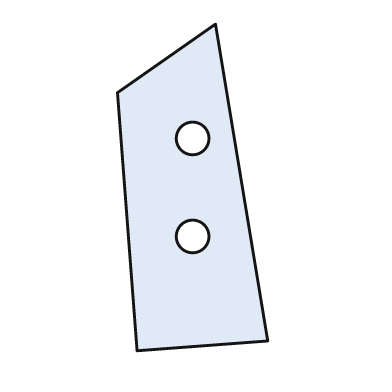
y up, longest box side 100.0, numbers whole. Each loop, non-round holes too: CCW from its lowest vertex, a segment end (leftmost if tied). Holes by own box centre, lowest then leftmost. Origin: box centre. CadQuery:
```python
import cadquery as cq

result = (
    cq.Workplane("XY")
    .moveTo(-17.0, -50.0)
    .lineTo(23.0, -47.0)
    .lineTo(7.0, 50.0)
    .lineTo(-23.0, 29.0)
    .close()
    .moveTo(0.0, -15.0)
    .circle(5.0)
    .moveTo(0.0, 15.0)
    .circle(5.0)
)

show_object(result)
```